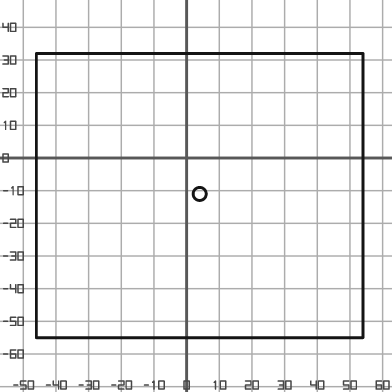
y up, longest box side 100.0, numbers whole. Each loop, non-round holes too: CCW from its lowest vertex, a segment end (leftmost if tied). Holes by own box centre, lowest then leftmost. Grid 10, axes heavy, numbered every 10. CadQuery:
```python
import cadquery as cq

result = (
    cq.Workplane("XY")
    .moveTo(-46.0, -55.0)
    .lineTo(54.0, -55.0)
    .lineTo(54.0, 32.0)
    .lineTo(-46.0, 32.0)
    .close()
    .moveTo(4.0, -11.0)
    .circle(2.0)
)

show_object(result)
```